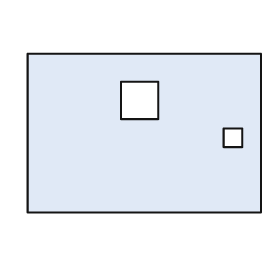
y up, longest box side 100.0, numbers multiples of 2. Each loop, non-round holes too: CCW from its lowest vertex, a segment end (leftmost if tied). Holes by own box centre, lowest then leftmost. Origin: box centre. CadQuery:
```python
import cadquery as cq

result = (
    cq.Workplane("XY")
    .moveTo(-50.0, -34.0)
    .lineTo(50.0, -34.0)
    .lineTo(50.0, 34.0)
    .lineTo(-50.0, 34.0)
    .close()
    .moveTo(34.0, -6.0)
    .lineTo(42.0, -6.0)
    .lineTo(42.0, 2.0)
    .lineTo(34.0, 2.0)
    .close()
    .moveTo(-10.0, 6.0)
    .lineTo(6.0, 6.0)
    .lineTo(6.0, 22.0)
    .lineTo(-10.0, 22.0)
    .close()
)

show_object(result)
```